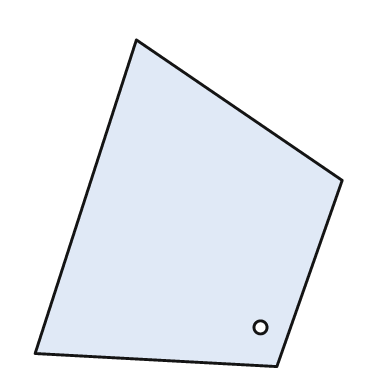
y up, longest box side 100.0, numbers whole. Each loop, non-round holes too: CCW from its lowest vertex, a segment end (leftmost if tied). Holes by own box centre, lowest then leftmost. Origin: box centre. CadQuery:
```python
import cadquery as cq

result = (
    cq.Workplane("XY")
    .moveTo(27.0, -50.0)
    .lineTo(47.0, 7.0)
    .lineTo(-16.0, 50.0)
    .lineTo(-47.0, -46.0)
    .close()
    .moveTo(22.0, -38.0)
    .circle(2.0)
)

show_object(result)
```